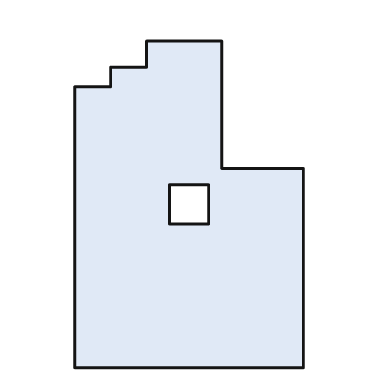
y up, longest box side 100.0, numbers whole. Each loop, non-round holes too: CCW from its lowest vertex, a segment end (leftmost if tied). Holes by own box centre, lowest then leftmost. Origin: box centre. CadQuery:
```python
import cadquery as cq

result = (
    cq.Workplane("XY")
    .moveTo(-35.0, -50.0)
    .lineTo(35.0, -50.0)
    .lineTo(35.0, 11.0)
    .lineTo(10.0, 11.0)
    .lineTo(10.0, 50.0)
    .lineTo(-13.0, 50.0)
    .lineTo(-13.0, 42.0)
    .lineTo(-24.0, 42.0)
    .lineTo(-24.0, 36.0)
    .lineTo(-35.0, 36.0)
    .close()
    .moveTo(-6.0, -6.0)
    .lineTo(6.0, -6.0)
    .lineTo(6.0, 6.0)
    .lineTo(-6.0, 6.0)
    .close()
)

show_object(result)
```